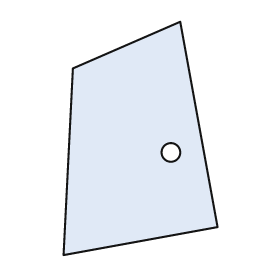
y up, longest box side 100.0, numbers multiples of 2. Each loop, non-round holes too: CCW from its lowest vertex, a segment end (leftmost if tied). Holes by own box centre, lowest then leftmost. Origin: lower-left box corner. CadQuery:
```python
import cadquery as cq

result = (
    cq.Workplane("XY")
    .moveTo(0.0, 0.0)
    .lineTo(66.0, 12.0)
    .lineTo(50.0, 100.0)
    .lineTo(4.0, 80.0)
    .close()
    .moveTo(46.0, 44.0)
    .circle(4.0)
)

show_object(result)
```